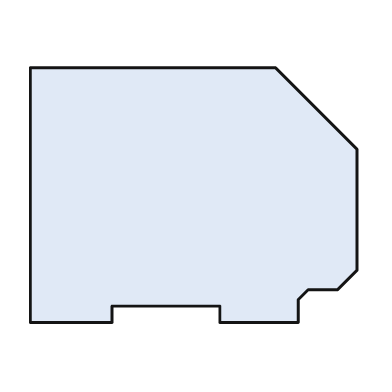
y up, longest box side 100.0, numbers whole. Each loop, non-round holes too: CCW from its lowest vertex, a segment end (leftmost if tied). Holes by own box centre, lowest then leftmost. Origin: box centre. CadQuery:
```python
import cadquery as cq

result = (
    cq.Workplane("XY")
    .moveTo(-50.0, -39.0)
    .lineTo(-25.0, -39.0)
    .lineTo(-25.0, -34.0)
    .lineTo(8.0, -34.0)
    .lineTo(8.0, -39.0)
    .lineTo(32.0, -39.0)
    .lineTo(32.0, -32.0)
    .lineTo(35.0, -29.0)
    .lineTo(44.0, -29.0)
    .lineTo(50.0, -23.0)
    .lineTo(50.0, 14.0)
    .lineTo(25.0, 39.0)
    .lineTo(-50.0, 39.0)
    .close()
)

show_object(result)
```